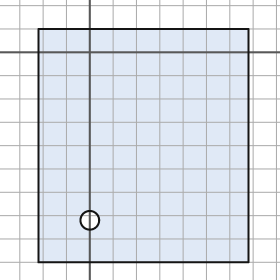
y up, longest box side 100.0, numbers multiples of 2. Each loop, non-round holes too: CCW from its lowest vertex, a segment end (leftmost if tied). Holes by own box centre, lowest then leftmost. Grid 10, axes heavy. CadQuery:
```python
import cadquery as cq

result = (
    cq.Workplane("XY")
    .moveTo(-22.0, -90.0)
    .lineTo(68.0, -90.0)
    .lineTo(68.0, 10.0)
    .lineTo(-22.0, 10.0)
    .close()
    .moveTo(0.0, -72.0)
    .circle(4.0)
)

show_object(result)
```